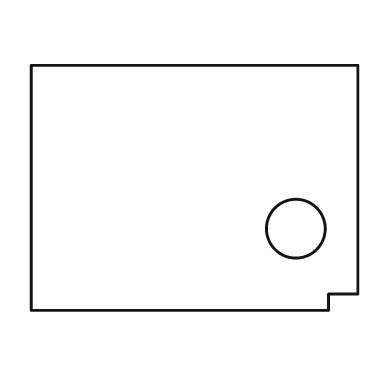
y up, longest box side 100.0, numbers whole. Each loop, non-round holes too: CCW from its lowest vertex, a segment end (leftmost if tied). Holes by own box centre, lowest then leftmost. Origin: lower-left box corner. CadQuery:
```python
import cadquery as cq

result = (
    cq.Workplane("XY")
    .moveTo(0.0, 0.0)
    .lineTo(91.0, 0.0)
    .lineTo(91.0, 5.0)
    .lineTo(100.0, 5.0)
    .lineTo(100.0, 75.0)
    .lineTo(0.0, 75.0)
    .close()
    .moveTo(81.0, 25.0)
    .circle(9.0)
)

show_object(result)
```